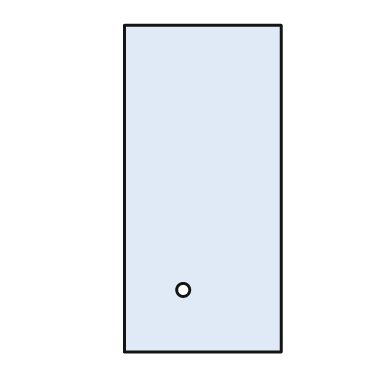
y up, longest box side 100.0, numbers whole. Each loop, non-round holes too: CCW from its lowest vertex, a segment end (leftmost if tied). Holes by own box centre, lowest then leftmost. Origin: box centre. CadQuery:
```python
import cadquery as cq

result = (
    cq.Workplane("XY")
    .moveTo(-24.0, -50.0)
    .lineTo(24.0, -50.0)
    .lineTo(24.0, 50.0)
    .lineTo(-24.0, 50.0)
    .close()
    .moveTo(-6.0, -31.0)
    .circle(2.0)
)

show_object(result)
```